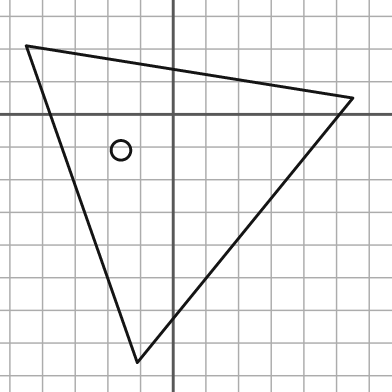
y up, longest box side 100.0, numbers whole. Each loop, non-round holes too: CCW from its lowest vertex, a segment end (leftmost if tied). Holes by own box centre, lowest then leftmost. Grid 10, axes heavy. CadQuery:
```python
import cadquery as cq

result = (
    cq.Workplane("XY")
    .moveTo(-11.0, -76.0)
    .lineTo(55.0, 5.0)
    .lineTo(-45.0, 21.0)
    .close()
    .moveTo(-16.0, -11.0)
    .circle(3.0)
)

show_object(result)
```